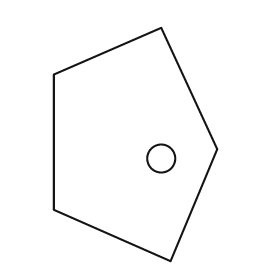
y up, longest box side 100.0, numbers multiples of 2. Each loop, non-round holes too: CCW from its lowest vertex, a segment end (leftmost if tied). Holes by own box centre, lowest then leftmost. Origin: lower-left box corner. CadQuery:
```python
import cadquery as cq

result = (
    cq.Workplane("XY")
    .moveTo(50.0, 0.0)
    .lineTo(70.0, 48.0)
    .lineTo(46.0, 100.0)
    .lineTo(0.0, 80.0)
    .lineTo(0.0, 22.0)
    .close()
    .moveTo(46.0, 44.0)
    .circle(6.0)
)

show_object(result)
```